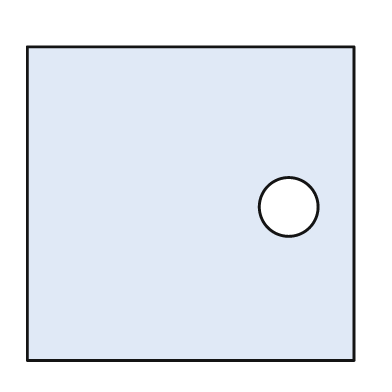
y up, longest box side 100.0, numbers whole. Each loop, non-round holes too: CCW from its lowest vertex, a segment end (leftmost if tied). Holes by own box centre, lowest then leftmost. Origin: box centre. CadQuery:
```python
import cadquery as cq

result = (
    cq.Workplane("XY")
    .moveTo(-50.0, -48.0)
    .lineTo(50.0, -48.0)
    .lineTo(50.0, 48.0)
    .lineTo(-50.0, 48.0)
    .close()
    .moveTo(30.0, -1.0)
    .circle(9.0)
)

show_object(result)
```